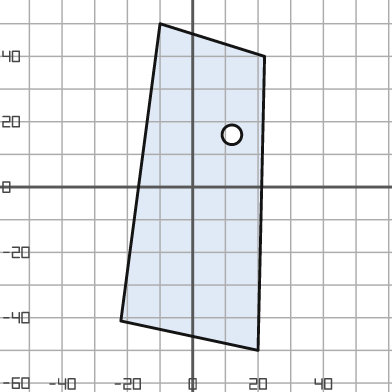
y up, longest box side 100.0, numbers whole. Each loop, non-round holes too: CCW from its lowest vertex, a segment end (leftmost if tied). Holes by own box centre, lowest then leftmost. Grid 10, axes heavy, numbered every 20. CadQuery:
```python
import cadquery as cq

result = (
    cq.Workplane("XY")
    .moveTo(20.0, -50.0)
    .lineTo(22.0, 40.0)
    .lineTo(-10.0, 50.0)
    .lineTo(-22.0, -41.0)
    .close()
    .moveTo(12.0, 16.0)
    .circle(3.0)
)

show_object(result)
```